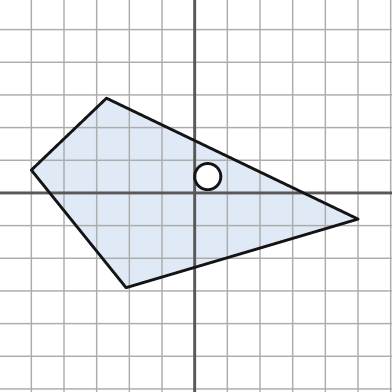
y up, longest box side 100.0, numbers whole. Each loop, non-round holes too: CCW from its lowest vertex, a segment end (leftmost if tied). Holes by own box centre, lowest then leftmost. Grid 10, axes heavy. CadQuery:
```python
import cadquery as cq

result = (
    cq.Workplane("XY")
    .moveTo(-21.0, -29.0)
    .lineTo(50.0, -8.0)
    .lineTo(-27.0, 29.0)
    .lineTo(-50.0, 7.0)
    .close()
    .moveTo(4.0, 5.0)
    .circle(4.0)
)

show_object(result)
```